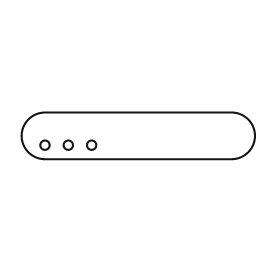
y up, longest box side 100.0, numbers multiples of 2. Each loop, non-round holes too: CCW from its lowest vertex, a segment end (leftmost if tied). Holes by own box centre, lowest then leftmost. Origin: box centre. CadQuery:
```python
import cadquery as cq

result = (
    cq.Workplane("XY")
    .moveTo(-40.0, -10.0)
    .lineTo(40.0, -10.0)
    .threePointArc((50.0, 0.0), (40.0, 10.0))
    .lineTo(-40.0, 10.0)
    .threePointArc((-50.0, 0.0), (-40.0, -10.0))
    .close()
    .moveTo(-40.0, -4.0)
    .circle(2.0)
    .moveTo(-30.0, -4.0)
    .circle(2.0)
    .moveTo(-20.0, -4.0)
    .circle(2.0)
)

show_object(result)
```